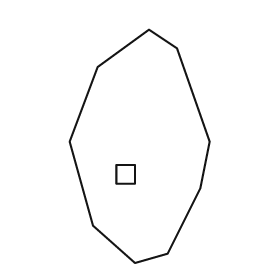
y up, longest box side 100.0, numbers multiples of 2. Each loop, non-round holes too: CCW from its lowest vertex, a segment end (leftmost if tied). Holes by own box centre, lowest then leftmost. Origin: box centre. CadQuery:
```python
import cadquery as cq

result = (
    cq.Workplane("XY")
    .moveTo(-2.0, -50.0)
    .lineTo(12.0, -46.0)
    .lineTo(26.0, -18.0)
    .lineTo(30.0, 2.0)
    .lineTo(16.0, 42.0)
    .lineTo(4.0, 50.0)
    .lineTo(-18.0, 34.0)
    .lineTo(-30.0, 2.0)
    .lineTo(-20.0, -34.0)
    .close()
    .moveTo(-10.0, -16.0)
    .lineTo(-2.0, -16.0)
    .lineTo(-2.0, -8.0)
    .lineTo(-10.0, -8.0)
    .close()
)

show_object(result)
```